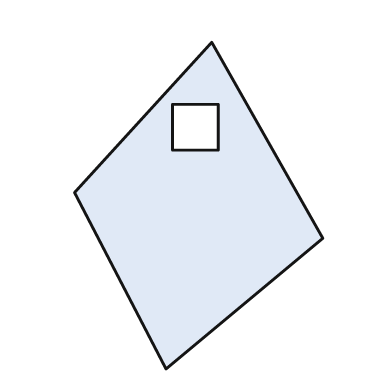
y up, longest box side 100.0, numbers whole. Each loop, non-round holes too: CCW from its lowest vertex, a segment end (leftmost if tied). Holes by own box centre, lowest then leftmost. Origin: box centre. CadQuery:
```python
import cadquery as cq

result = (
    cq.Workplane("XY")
    .moveTo(-10.0, -50.0)
    .lineTo(38.0, -10.0)
    .lineTo(4.0, 50.0)
    .lineTo(-38.0, 4.0)
    .close()
    .moveTo(-8.0, 17.0)
    .lineTo(6.0, 17.0)
    .lineTo(6.0, 31.0)
    .lineTo(-8.0, 31.0)
    .close()
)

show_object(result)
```